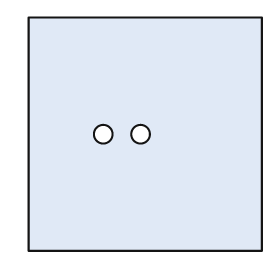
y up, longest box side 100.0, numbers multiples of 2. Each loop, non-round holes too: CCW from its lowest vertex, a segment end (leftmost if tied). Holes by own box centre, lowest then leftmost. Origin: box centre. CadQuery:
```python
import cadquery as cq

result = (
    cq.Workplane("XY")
    .moveTo(-50.0, -50.0)
    .lineTo(50.0, -50.0)
    .lineTo(50.0, 50.0)
    .lineTo(-50.0, 50.0)
    .close()
    .moveTo(-18.0, 0.0)
    .circle(4.0)
    .moveTo(-2.0, 0.0)
    .circle(4.0)
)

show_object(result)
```